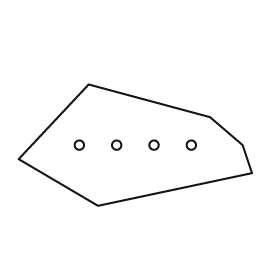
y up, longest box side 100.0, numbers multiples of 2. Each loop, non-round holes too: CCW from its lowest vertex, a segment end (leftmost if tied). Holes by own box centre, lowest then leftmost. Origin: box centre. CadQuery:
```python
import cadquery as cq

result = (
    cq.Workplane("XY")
    .moveTo(-16.0, -26.0)
    .lineTo(50.0, -12.0)
    .lineTo(46.0, 0.0)
    .lineTo(32.0, 12.0)
    .lineTo(-20.0, 26.0)
    .lineTo(-50.0, -6.0)
    .close()
    .moveTo(-24.0, 0.0)
    .circle(2.0)
    .moveTo(-8.0, 0.0)
    .circle(2.0)
    .moveTo(8.0, 0.0)
    .circle(2.0)
    .moveTo(24.0, 0.0)
    .circle(2.0)
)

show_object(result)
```